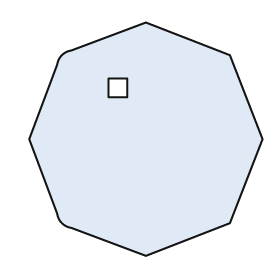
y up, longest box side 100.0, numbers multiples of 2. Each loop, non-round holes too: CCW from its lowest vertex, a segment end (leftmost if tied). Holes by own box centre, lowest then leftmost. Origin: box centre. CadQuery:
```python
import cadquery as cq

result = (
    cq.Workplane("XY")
    .moveTo(0.0, -50.0)
    .lineTo(36.0, -36.0)
    .lineTo(50.0, 0.0)
    .lineTo(36.0, 36.0)
    .lineTo(0.0, 50.0)
    .lineTo(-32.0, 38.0)
    .threePointArc((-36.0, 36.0), (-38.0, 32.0))
    .lineTo(-50.0, 0.0)
    .lineTo(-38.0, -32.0)
    .threePointArc((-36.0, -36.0), (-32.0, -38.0))
    .close()
    .moveTo(-16.0, 18.0)
    .lineTo(-8.0, 18.0)
    .lineTo(-8.0, 26.0)
    .lineTo(-16.0, 26.0)
    .close()
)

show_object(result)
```